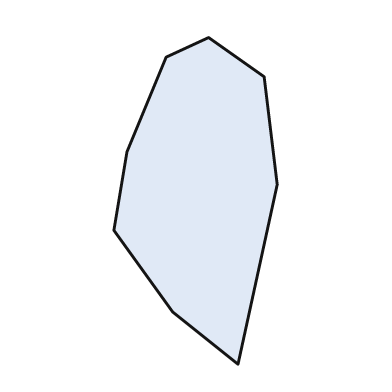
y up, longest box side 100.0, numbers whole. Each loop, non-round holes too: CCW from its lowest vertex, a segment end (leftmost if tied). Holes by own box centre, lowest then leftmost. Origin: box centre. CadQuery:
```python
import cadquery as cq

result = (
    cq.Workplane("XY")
    .moveTo(13.0, -50.0)
    .lineTo(25.0, 5.0)
    .lineTo(21.0, 38.0)
    .lineTo(4.0, 50.0)
    .lineTo(-9.0, 44.0)
    .lineTo(-21.0, 15.0)
    .lineTo(-25.0, -9.0)
    .lineTo(-7.0, -34.0)
    .close()
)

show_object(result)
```